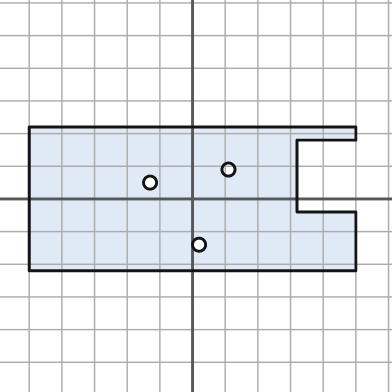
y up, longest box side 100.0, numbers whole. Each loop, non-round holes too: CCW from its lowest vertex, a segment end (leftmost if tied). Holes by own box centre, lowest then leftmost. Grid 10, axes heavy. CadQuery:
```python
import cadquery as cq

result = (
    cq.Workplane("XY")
    .moveTo(-50.0, -22.0)
    .lineTo(50.0, -22.0)
    .lineTo(50.0, -4.0)
    .lineTo(32.0, -4.0)
    .lineTo(32.0, 18.0)
    .lineTo(50.0, 18.0)
    .lineTo(50.0, 22.0)
    .lineTo(-50.0, 22.0)
    .close()
    .moveTo(2.0, -14.0)
    .circle(2.0)
    .moveTo(-13.0, 5.0)
    .circle(2.0)
    .moveTo(11.0, 9.0)
    .circle(2.0)
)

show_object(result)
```